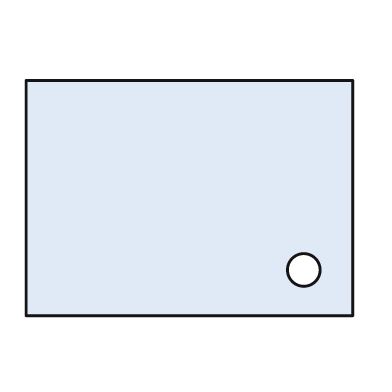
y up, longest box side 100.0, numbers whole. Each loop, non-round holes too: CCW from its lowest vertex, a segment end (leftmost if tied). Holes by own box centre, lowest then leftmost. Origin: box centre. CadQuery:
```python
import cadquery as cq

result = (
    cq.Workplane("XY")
    .moveTo(-50.0, -36.0)
    .lineTo(50.0, -36.0)
    .lineTo(50.0, 36.0)
    .lineTo(-50.0, 36.0)
    .close()
    .moveTo(35.0, -22.0)
    .circle(5.0)
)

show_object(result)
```